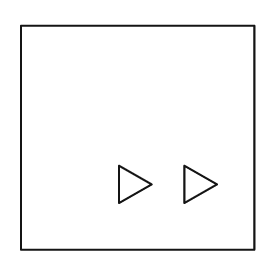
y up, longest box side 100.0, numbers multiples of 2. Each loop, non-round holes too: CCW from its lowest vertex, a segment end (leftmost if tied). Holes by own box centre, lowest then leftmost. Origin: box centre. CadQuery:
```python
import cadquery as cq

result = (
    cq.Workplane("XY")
    .moveTo(-50.0, -48.0)
    .lineTo(50.0, -48.0)
    .lineTo(50.0, 48.0)
    .lineTo(-50.0, 48.0)
    .close()
    .moveTo(-8.0, -28.0)
    .lineTo(6.0, -20.0)
    .lineTo(-8.0, -12.0)
    .close()
    .moveTo(20.0, -28.0)
    .lineTo(34.0, -20.0)
    .lineTo(20.0, -12.0)
    .close()
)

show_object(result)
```